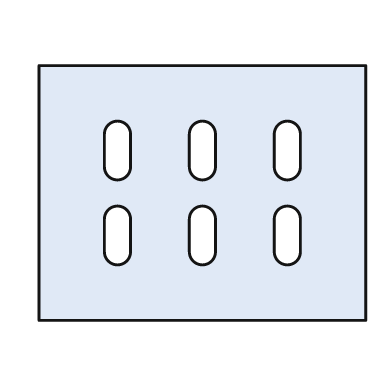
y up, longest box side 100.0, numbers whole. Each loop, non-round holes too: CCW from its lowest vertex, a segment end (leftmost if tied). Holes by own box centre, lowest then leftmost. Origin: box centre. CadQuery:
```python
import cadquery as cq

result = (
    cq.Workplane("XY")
    .moveTo(-50.0, -39.0)
    .lineTo(50.0, -39.0)
    .lineTo(50.0, 39.0)
    .lineTo(-50.0, 39.0)
    .close()
    .moveTo(-30.0, -18.0)
    .threePointArc((-26.0, -22.0), (-22.0, -18.0))
    .lineTo(-22.0, -8.0)
    .threePointArc((-26.0, -4.0), (-30.0, -8.0))
    .close()
    .moveTo(-4.0, -18.0)
    .threePointArc((0.0, -22.0), (4.0, -18.0))
    .lineTo(4.0, -8.0)
    .threePointArc((0.0, -4.0), (-4.0, -8.0))
    .close()
    .moveTo(22.0, -18.0)
    .threePointArc((26.0, -22.0), (30.0, -18.0))
    .lineTo(30.0, -8.0)
    .threePointArc((26.0, -4.0), (22.0, -8.0))
    .close()
    .moveTo(-30.0, 8.0)
    .threePointArc((-26.0, 4.0), (-22.0, 8.0))
    .lineTo(-22.0, 18.0)
    .threePointArc((-26.0, 22.0), (-30.0, 18.0))
    .close()
    .moveTo(-4.0, 8.0)
    .threePointArc((0.0, 4.0), (4.0, 8.0))
    .lineTo(4.0, 18.0)
    .threePointArc((0.0, 22.0), (-4.0, 18.0))
    .close()
    .moveTo(22.0, 8.0)
    .threePointArc((26.0, 4.0), (30.0, 8.0))
    .lineTo(30.0, 18.0)
    .threePointArc((26.0, 22.0), (22.0, 18.0))
    .close()
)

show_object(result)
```